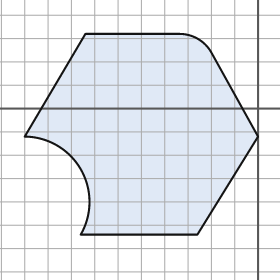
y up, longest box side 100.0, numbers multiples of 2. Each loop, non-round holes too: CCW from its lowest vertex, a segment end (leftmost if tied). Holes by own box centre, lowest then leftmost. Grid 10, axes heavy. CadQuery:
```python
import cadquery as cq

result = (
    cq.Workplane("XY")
    .moveTo(-76.0, -54.0)
    .lineTo(-26.0, -54.0)
    .lineTo(0.0, -12.0)
    .lineTo(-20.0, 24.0)
    .threePointArc((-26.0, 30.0), (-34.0, 32.0))
    .lineTo(-74.0, 32.0)
    .lineTo(-100.0, -12.0)
    .threePointArc((-76.0, -26.0), (-76.0, -54.0))
    .close()
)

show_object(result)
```